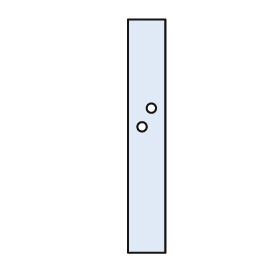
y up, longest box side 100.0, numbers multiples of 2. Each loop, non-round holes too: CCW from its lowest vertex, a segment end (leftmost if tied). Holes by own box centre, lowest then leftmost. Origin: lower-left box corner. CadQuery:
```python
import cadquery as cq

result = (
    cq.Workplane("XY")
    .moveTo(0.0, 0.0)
    .lineTo(16.0, 0.0)
    .lineTo(16.0, 100.0)
    .lineTo(0.0, 100.0)
    .close()
    .moveTo(6.0, 54.0)
    .circle(2.0)
    .moveTo(10.0, 62.0)
    .circle(2.0)
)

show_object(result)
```